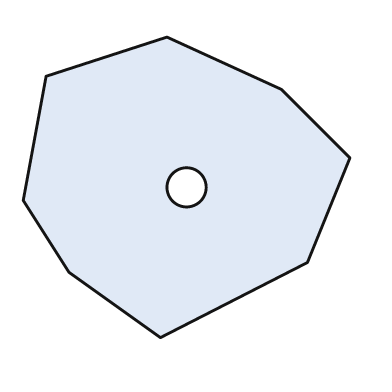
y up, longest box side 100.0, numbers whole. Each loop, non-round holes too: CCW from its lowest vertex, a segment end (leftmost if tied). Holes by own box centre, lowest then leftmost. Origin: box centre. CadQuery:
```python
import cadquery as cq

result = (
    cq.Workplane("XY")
    .moveTo(-8.0, -46.0)
    .lineTo(37.0, -23.0)
    .lineTo(50.0, 9.0)
    .lineTo(29.0, 30.0)
    .lineTo(-6.0, 46.0)
    .lineTo(-43.0, 34.0)
    .lineTo(-50.0, -4.0)
    .lineTo(-36.0, -26.0)
    .close()
    .moveTo(0.0, 0.0)
    .circle(6.0)
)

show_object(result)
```